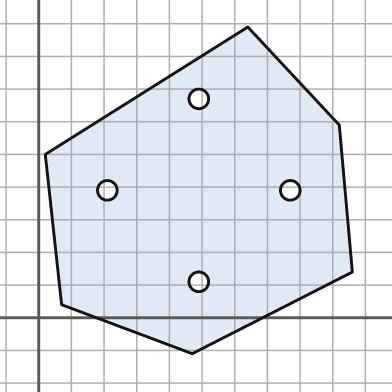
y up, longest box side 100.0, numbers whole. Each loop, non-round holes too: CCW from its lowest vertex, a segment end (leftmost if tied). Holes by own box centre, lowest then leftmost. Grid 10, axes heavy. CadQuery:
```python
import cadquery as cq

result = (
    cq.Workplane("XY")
    .moveTo(47.0, -11.0)
    .lineTo(96.0, 14.0)
    .lineTo(92.0, 59.0)
    .lineTo(64.0, 89.0)
    .lineTo(2.0, 50.0)
    .lineTo(7.0, 4.0)
    .close()
    .moveTo(49.0, 11.0)
    .circle(3.0)
    .moveTo(21.0, 39.0)
    .circle(3.0)
    .moveTo(77.0, 39.0)
    .circle(3.0)
    .moveTo(49.0, 67.0)
    .circle(3.0)
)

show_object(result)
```